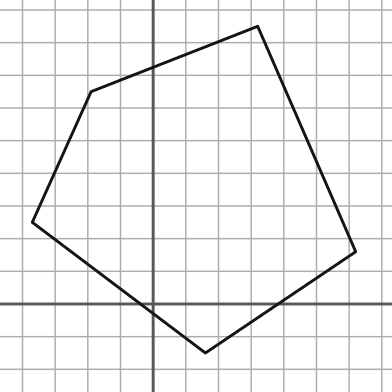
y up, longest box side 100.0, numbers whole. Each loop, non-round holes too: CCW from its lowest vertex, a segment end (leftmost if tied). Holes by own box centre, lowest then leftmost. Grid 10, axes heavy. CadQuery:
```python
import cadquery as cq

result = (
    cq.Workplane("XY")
    .moveTo(16.0, -15.0)
    .lineTo(62.0, 16.0)
    .lineTo(32.0, 85.0)
    .lineTo(-19.0, 65.0)
    .lineTo(-37.0, 25.0)
    .close()
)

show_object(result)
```